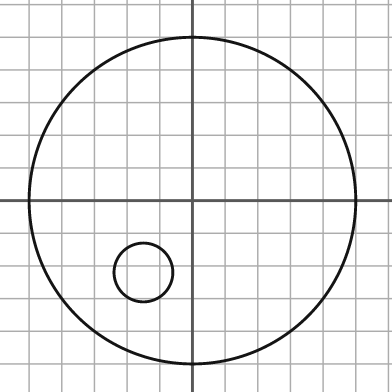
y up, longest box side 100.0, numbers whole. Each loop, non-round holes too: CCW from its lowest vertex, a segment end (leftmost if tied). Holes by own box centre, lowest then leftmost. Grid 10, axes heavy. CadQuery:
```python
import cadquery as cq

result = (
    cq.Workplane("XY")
    .moveTo(0.0, 0.0)
    .circle(50.0)
    .moveTo(-15.0, -22.0)
    .circle(9.0)
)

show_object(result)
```